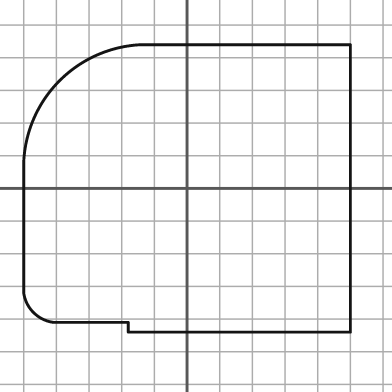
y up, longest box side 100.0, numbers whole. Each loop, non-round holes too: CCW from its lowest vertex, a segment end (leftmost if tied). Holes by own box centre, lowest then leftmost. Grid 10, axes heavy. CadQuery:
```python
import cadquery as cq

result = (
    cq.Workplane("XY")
    .moveTo(-18.0, -44.0)
    .lineTo(50.0, -44.0)
    .lineTo(50.0, 44.0)
    .lineTo(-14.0, 44.0)
    .threePointArc((-39.0, 33.0), (-50.0, 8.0))
    .lineTo(-50.0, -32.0)
    .threePointArc((-47.0, -38.0), (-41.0, -41.0))
    .lineTo(-18.0, -41.0)
    .close()
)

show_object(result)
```